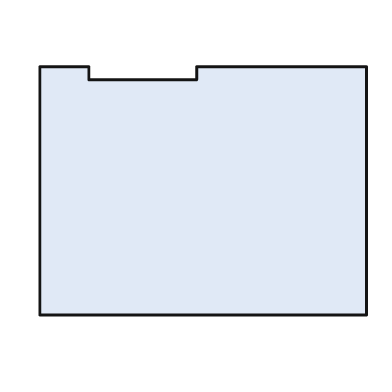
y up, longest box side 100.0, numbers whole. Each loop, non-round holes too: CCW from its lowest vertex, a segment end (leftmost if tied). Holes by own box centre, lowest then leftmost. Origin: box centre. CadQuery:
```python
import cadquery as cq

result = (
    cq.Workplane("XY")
    .moveTo(-50.0, -38.0)
    .lineTo(50.0, -38.0)
    .lineTo(50.0, 38.0)
    .lineTo(-2.0, 38.0)
    .lineTo(-2.0, 34.0)
    .lineTo(-35.0, 34.0)
    .lineTo(-35.0, 38.0)
    .lineTo(-50.0, 38.0)
    .close()
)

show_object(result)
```